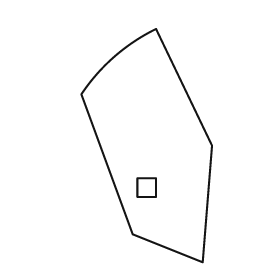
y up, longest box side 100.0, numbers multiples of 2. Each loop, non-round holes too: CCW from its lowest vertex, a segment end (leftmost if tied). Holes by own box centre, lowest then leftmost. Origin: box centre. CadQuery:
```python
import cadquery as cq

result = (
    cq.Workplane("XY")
    .moveTo(24.0, -50.0)
    .lineTo(28.0, 0.0)
    .lineTo(4.0, 50.0)
    .threePointArc((-14.0, 38.0), (-28.0, 22.0))
    .lineTo(-6.0, -38.0)
    .close()
    .moveTo(-4.0, -22.0)
    .lineTo(4.0, -22.0)
    .lineTo(4.0, -14.0)
    .lineTo(-4.0, -14.0)
    .close()
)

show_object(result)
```